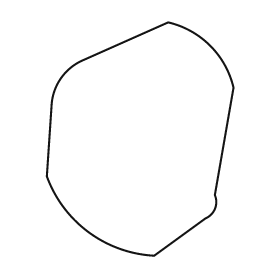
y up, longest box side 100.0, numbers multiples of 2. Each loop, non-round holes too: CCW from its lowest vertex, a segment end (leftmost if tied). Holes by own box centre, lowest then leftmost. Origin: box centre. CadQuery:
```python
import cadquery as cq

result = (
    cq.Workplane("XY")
    .moveTo(6.0, -50.0)
    .lineTo(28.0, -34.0)
    .threePointArc((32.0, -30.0), (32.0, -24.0))
    .lineTo(40.0, 22.0)
    .threePointArc((30.0, 40.0), (12.0, 50.0))
    .lineTo(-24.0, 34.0)
    .threePointArc((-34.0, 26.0), (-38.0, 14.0))
    .lineTo(-40.0, -16.0)
    .threePointArc((-22.0, -40.0), (6.0, -50.0))
    .close()
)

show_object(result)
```